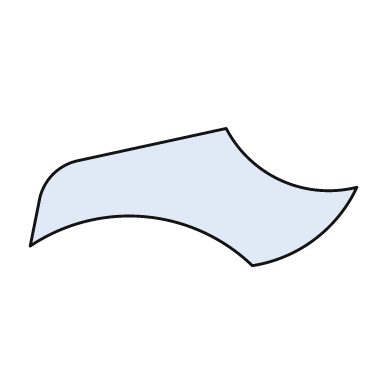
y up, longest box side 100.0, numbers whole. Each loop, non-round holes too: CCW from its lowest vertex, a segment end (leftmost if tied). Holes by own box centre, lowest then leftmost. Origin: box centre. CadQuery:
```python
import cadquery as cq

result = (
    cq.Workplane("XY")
    .moveTo(18.0, -21.0)
    .threePointArc((37.0, -13.0), (50.0, 3.0))
    .threePointArc((27.0, 5.0), (10.0, 21.0))
    .lineTo(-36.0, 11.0)
    .threePointArc((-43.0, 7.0), (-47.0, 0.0))
    .lineTo(-50.0, -15.0)
    .threePointArc((-15.0, -6.0), (18.0, -21.0))
    .close()
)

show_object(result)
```